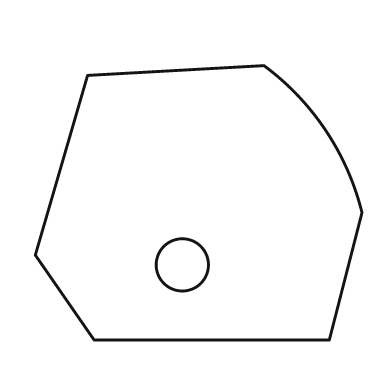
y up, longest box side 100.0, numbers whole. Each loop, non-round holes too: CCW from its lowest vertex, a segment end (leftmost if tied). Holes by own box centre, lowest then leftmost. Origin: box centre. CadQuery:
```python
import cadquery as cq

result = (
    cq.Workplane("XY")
    .moveTo(-32.0, -42.0)
    .lineTo(40.0, -42.0)
    .lineTo(50.0, -3.0)
    .threePointArc((39.0, 22.0), (20.0, 42.0))
    .lineTo(-34.0, 39.0)
    .lineTo(-50.0, -16.0)
    .close()
    .moveTo(-5.0, -19.0)
    .circle(8.0)
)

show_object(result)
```